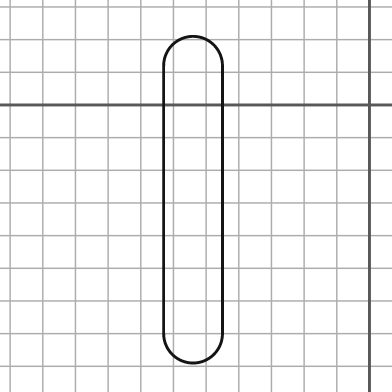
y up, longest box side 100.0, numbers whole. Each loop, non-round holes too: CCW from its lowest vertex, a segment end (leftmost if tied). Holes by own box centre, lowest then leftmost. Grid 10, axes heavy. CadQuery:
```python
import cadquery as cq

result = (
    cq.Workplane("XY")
    .moveTo(-63.0, -70.0)
    .threePointArc((-54.0, -79.0), (-45.0, -70.0))
    .lineTo(-45.0, 12.0)
    .threePointArc((-54.0, 21.0), (-63.0, 12.0))
    .close()
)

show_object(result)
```